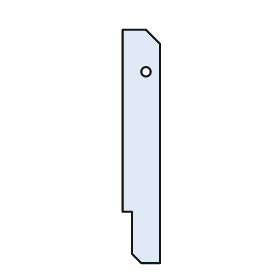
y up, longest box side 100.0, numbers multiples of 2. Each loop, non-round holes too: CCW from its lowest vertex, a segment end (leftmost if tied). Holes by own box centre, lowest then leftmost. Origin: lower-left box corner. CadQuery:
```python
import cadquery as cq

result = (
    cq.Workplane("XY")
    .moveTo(8.0, 0.0)
    .lineTo(16.0, 0.0)
    .lineTo(16.0, 94.0)
    .lineTo(10.0, 100.0)
    .lineTo(0.0, 100.0)
    .lineTo(0.0, 22.0)
    .lineTo(4.0, 22.0)
    .lineTo(4.0, 4.0)
    .close()
    .moveTo(10.0, 82.0)
    .circle(2.0)
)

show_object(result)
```